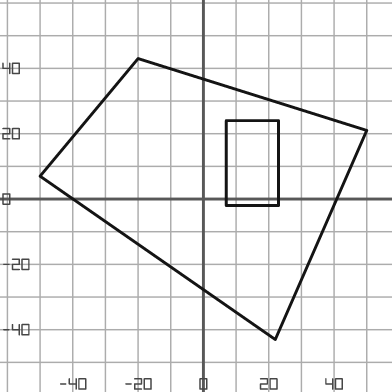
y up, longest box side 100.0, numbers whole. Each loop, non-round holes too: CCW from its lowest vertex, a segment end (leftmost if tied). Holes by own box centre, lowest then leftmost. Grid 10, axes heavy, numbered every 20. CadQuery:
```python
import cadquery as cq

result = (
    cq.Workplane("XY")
    .moveTo(22.0, -43.0)
    .lineTo(50.0, 21.0)
    .lineTo(-20.0, 43.0)
    .lineTo(-50.0, 7.0)
    .close()
    .moveTo(7.0, -2.0)
    .lineTo(23.0, -2.0)
    .lineTo(23.0, 24.0)
    .lineTo(7.0, 24.0)
    .close()
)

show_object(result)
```